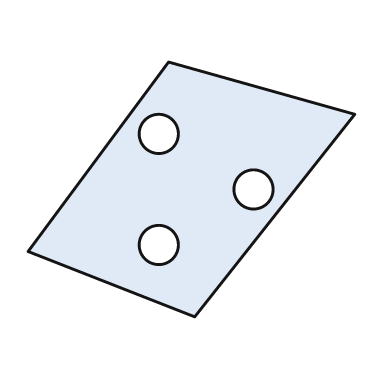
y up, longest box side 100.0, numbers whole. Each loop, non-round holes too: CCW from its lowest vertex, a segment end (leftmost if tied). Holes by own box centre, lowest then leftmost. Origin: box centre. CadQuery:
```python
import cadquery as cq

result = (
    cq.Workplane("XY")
    .moveTo(1.0, -39.0)
    .lineTo(50.0, 23.0)
    .lineTo(-7.0, 39.0)
    .lineTo(-50.0, -19.0)
    .close()
    .moveTo(-10.0, -17.0)
    .circle(6.0)
    .moveTo(19.0, 0.0)
    .circle(6.0)
    .moveTo(-10.0, 17.0)
    .circle(6.0)
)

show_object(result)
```